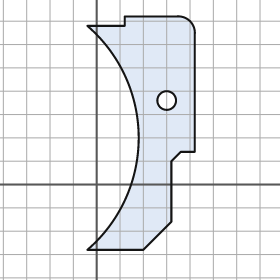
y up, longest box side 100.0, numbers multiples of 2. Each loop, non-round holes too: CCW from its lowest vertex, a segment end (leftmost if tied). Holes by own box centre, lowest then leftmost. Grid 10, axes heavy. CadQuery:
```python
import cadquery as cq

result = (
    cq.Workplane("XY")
    .moveTo(-4.0, -28.0)
    .lineTo(20.0, -28.0)
    .lineTo(32.0, -16.0)
    .lineTo(32.0, 10.0)
    .lineTo(36.0, 14.0)
    .lineTo(42.0, 14.0)
    .lineTo(42.0, 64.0)
    .threePointArc((40.0, 70.0), (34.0, 72.0))
    .lineTo(12.0, 72.0)
    .lineTo(12.0, 68.0)
    .lineTo(-4.0, 68.0)
    .threePointArc((18.0, 20.0), (-4.0, -28.0))
    .close()
    .moveTo(30.0, 36.0)
    .circle(4.0)
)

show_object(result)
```